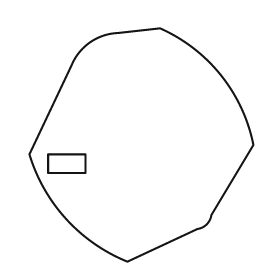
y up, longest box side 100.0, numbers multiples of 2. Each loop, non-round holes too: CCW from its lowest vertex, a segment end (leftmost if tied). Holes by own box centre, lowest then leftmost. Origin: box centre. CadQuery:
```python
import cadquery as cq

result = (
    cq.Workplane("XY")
    .moveTo(-6.0, -50.0)
    .lineTo(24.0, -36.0)
    .threePointArc((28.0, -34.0), (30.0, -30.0))
    .lineTo(48.0, 0.0)
    .threePointArc((34.0, 30.0), (8.0, 50.0))
    .lineTo(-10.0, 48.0)
    .threePointArc((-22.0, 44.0), (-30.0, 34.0))
    .lineTo(-48.0, -4.0)
    .threePointArc((-32.0, -32.0), (-6.0, -50.0))
    .close()
    .moveTo(-40.0, -12.0)
    .lineTo(-24.0, -12.0)
    .lineTo(-24.0, -4.0)
    .lineTo(-40.0, -4.0)
    .close()
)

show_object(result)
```